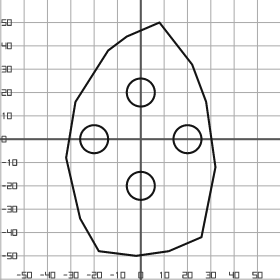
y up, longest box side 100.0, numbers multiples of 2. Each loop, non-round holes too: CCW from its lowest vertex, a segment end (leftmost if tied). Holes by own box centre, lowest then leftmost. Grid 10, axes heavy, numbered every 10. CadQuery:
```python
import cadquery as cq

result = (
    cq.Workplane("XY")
    .moveTo(-2.0, -50.0)
    .lineTo(12.0, -48.0)
    .lineTo(26.0, -42.0)
    .lineTo(32.0, -12.0)
    .lineTo(28.0, 16.0)
    .lineTo(22.0, 32.0)
    .lineTo(8.0, 50.0)
    .lineTo(-6.0, 44.0)
    .lineTo(-14.0, 38.0)
    .lineTo(-28.0, 16.0)
    .lineTo(-32.0, -8.0)
    .lineTo(-26.0, -34.0)
    .lineTo(-18.0, -48.0)
    .close()
    .moveTo(0.0, -20.0)
    .circle(6.0)
    .moveTo(-20.0, 0.0)
    .circle(6.0)
    .moveTo(20.0, 0.0)
    .circle(6.0)
    .moveTo(0.0, 20.0)
    .circle(6.0)
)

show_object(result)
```